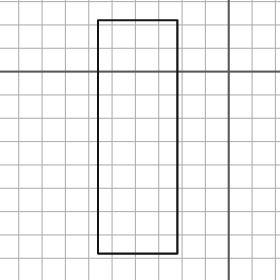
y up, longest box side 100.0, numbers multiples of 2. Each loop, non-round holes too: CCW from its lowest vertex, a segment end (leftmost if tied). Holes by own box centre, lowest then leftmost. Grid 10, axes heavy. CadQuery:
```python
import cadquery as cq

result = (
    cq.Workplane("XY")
    .moveTo(-56.0, -78.0)
    .lineTo(-22.0, -78.0)
    .lineTo(-22.0, 22.0)
    .lineTo(-56.0, 22.0)
    .close()
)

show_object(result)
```